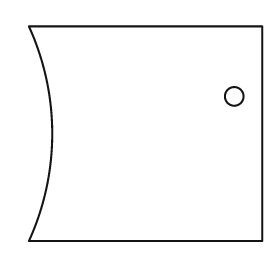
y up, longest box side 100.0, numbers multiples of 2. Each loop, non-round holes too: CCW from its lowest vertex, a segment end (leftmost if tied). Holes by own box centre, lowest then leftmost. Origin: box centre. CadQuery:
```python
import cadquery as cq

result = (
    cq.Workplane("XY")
    .moveTo(-50.0, -46.0)
    .lineTo(50.0, -46.0)
    .lineTo(50.0, 46.0)
    .lineTo(-50.0, 46.0)
    .threePointArc((-40.0, 0.0), (-50.0, -46.0))
    .close()
    .moveTo(38.0, 16.0)
    .circle(4.0)
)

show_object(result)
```